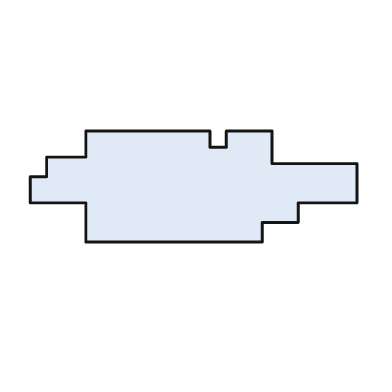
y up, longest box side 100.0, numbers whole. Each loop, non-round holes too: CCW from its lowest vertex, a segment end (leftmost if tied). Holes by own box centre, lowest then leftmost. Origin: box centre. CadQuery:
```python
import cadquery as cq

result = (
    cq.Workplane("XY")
    .moveTo(-33.0, -17.0)
    .lineTo(21.0, -17.0)
    .lineTo(21.0, -11.0)
    .lineTo(32.0, -11.0)
    .lineTo(32.0, -5.0)
    .lineTo(50.0, -5.0)
    .lineTo(50.0, 7.0)
    .lineTo(24.0, 7.0)
    .lineTo(24.0, 17.0)
    .lineTo(10.0, 17.0)
    .lineTo(10.0, 12.0)
    .lineTo(5.0, 12.0)
    .lineTo(5.0, 17.0)
    .lineTo(-33.0, 17.0)
    .lineTo(-33.0, 9.0)
    .lineTo(-45.0, 9.0)
    .lineTo(-45.0, 3.0)
    .lineTo(-50.0, 3.0)
    .lineTo(-50.0, -5.0)
    .lineTo(-33.0, -5.0)
    .close()
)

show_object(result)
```